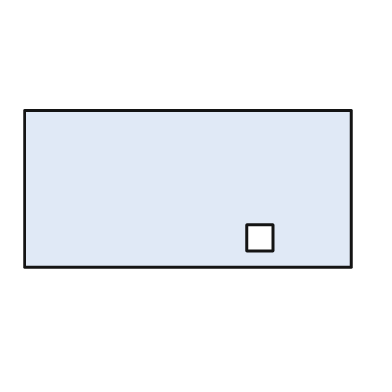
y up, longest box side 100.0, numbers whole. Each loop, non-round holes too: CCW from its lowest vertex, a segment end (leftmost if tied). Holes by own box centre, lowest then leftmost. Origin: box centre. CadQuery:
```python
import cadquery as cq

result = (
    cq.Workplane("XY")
    .moveTo(-50.0, -24.0)
    .lineTo(50.0, -24.0)
    .lineTo(50.0, 24.0)
    .lineTo(-50.0, 24.0)
    .close()
    .moveTo(18.0, -19.0)
    .lineTo(26.0, -19.0)
    .lineTo(26.0, -11.0)
    .lineTo(18.0, -11.0)
    .close()
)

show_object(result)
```